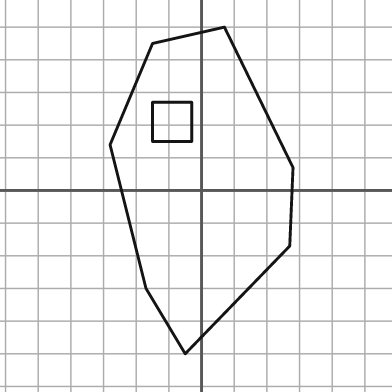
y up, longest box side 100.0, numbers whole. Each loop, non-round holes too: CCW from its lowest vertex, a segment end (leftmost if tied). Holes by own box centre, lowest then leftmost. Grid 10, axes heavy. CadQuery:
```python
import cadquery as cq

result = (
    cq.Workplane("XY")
    .moveTo(-5.0, -50.0)
    .lineTo(27.0, -17.0)
    .lineTo(28.0, 7.0)
    .lineTo(7.0, 50.0)
    .lineTo(-15.0, 45.0)
    .lineTo(-28.0, 14.0)
    .lineTo(-17.0, -30.0)
    .close()
    .moveTo(-15.0, 15.0)
    .lineTo(-3.0, 15.0)
    .lineTo(-3.0, 27.0)
    .lineTo(-15.0, 27.0)
    .close()
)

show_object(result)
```